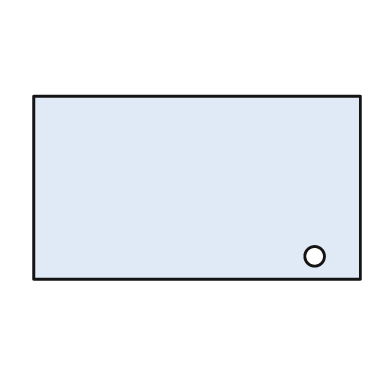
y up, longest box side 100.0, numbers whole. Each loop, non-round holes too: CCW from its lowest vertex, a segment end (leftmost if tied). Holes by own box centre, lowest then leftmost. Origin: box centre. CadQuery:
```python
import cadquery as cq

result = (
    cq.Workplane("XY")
    .moveTo(-50.0, -28.0)
    .lineTo(50.0, -28.0)
    .lineTo(50.0, 28.0)
    .lineTo(-50.0, 28.0)
    .close()
    .moveTo(36.0, -21.0)
    .circle(3.0)
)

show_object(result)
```